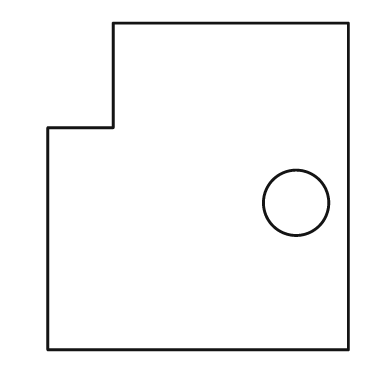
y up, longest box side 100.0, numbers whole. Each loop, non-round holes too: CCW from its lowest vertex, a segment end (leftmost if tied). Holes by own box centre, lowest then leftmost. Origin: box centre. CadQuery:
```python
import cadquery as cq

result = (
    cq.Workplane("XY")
    .moveTo(-46.0, -50.0)
    .lineTo(46.0, -50.0)
    .lineTo(46.0, 50.0)
    .lineTo(-26.0, 50.0)
    .lineTo(-26.0, 18.0)
    .lineTo(-46.0, 18.0)
    .close()
    .moveTo(30.0, -5.0)
    .circle(10.0)
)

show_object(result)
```